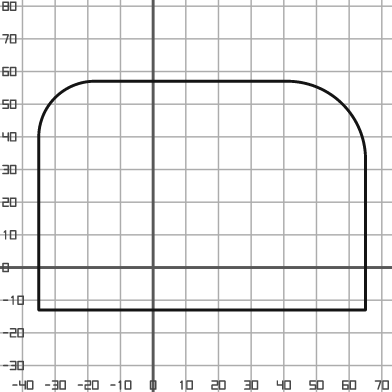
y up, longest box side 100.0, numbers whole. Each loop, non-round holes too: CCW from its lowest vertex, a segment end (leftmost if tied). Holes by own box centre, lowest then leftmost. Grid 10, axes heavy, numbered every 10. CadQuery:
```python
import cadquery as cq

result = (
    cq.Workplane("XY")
    .moveTo(-35.0, -13.0)
    .lineTo(65.0, -13.0)
    .lineTo(65.0, 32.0)
    .threePointArc((58.0, 50.0), (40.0, 57.0))
    .lineTo(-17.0, 57.0)
    .threePointArc((-30.0, 52.0), (-35.0, 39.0))
    .close()
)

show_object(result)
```